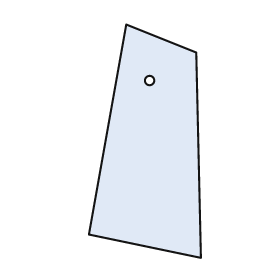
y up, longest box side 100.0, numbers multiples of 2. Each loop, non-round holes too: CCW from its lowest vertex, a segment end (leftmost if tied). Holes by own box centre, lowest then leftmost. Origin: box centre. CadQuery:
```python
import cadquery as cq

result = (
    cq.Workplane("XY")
    .moveTo(24.0, -50.0)
    .lineTo(22.0, 38.0)
    .lineTo(-8.0, 50.0)
    .lineTo(-24.0, -40.0)
    .close()
    .moveTo(2.0, 26.0)
    .circle(2.0)
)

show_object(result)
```